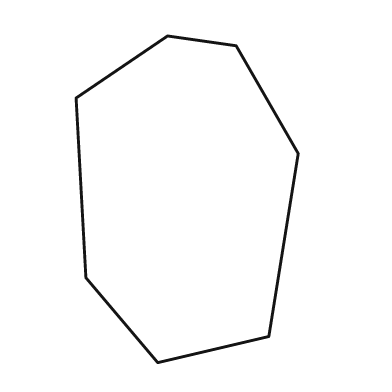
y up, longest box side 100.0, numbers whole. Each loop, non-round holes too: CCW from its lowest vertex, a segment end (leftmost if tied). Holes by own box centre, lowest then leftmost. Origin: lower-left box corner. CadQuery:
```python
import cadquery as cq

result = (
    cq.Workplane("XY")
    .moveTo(25.0, 0.0)
    .lineTo(59.0, 8.0)
    .lineTo(68.0, 64.0)
    .lineTo(49.0, 97.0)
    .lineTo(28.0, 100.0)
    .lineTo(0.0, 81.0)
    .lineTo(3.0, 26.0)
    .close()
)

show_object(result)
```